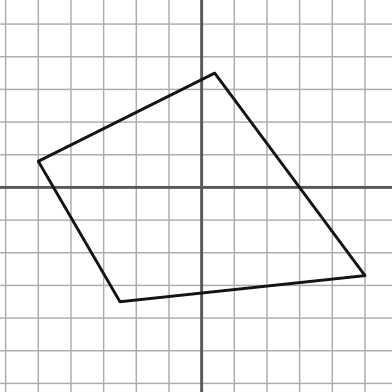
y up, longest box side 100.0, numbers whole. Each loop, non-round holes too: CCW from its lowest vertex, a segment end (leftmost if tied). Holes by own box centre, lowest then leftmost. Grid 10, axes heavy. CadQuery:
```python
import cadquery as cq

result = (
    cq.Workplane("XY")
    .moveTo(-25.0, -35.0)
    .lineTo(50.0, -27.0)
    .lineTo(4.0, 35.0)
    .lineTo(-50.0, 8.0)
    .close()
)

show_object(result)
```